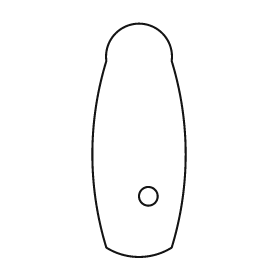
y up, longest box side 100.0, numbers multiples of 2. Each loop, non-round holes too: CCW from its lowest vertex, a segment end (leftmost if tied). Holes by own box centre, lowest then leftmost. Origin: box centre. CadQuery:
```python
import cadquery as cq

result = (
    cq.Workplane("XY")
    .moveTo(-14.0, -46.0)
    .threePointArc((0.0, -50.0), (14.0, -46.0))
    .threePointArc((20.0, -6.0), (14.0, 34.0))
    .threePointArc((0.0, 50.0), (-14.0, 34.0))
    .threePointArc((-20.0, -6.0), (-14.0, -46.0))
    .close()
    .moveTo(4.0, -24.0)
    .circle(4.0)
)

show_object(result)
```